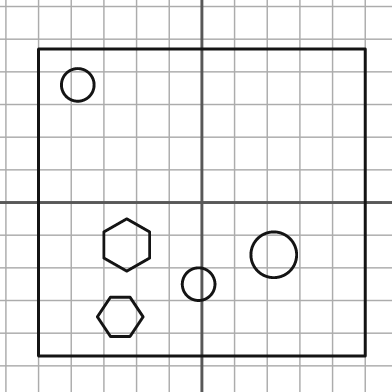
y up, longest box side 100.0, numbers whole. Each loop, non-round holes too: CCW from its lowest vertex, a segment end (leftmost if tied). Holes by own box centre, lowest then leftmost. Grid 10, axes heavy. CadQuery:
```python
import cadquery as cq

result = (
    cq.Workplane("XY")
    .moveTo(-50.0, -47.0)
    .lineTo(50.0, -47.0)
    .lineTo(50.0, 47.0)
    .lineTo(-50.0, 47.0)
    .close()
    .moveTo(-28.0, -41.0)
    .lineTo(-22.0, -41.0)
    .lineTo(-18.0, -35.0)
    .lineTo(-22.0, -29.0)
    .lineTo(-28.0, -29.0)
    .lineTo(-32.0, -35.0)
    .close()
    .moveTo(-1.0, -25.0)
    .circle(5.0)
    .moveTo(22.0, -16.0)
    .circle(7.0)
    .moveTo(-23.0, -21.0)
    .lineTo(-16.0, -17.0)
    .lineTo(-16.0, -9.0)
    .lineTo(-23.0, -5.0)
    .lineTo(-30.0, -9.0)
    .lineTo(-30.0, -17.0)
    .close()
    .moveTo(-38.0, 36.0)
    .circle(5.0)
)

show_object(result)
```